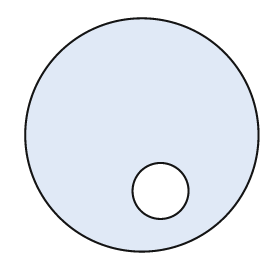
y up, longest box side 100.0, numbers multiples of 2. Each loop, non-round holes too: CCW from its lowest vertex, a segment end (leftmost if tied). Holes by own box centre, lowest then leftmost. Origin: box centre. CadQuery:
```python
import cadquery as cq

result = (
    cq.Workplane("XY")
    .moveTo(0.0, 0.0)
    .circle(50.0)
    .moveTo(8.0, -24.0)
    .circle(12.0)
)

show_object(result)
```